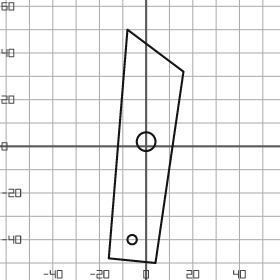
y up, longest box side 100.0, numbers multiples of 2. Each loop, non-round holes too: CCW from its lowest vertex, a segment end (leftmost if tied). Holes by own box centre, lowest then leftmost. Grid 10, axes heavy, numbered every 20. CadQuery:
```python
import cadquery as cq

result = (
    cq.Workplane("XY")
    .moveTo(4.0, -50.0)
    .lineTo(16.0, 32.0)
    .lineTo(-8.0, 50.0)
    .lineTo(-16.0, -48.0)
    .close()
    .moveTo(-6.0, -40.0)
    .circle(2.0)
    .moveTo(0.0, 2.0)
    .circle(4.0)
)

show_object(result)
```